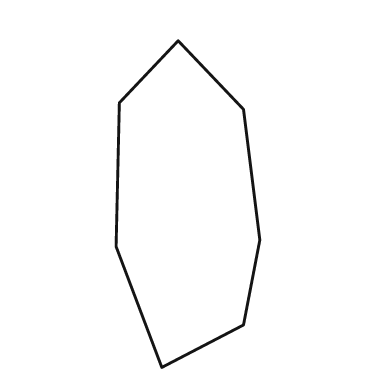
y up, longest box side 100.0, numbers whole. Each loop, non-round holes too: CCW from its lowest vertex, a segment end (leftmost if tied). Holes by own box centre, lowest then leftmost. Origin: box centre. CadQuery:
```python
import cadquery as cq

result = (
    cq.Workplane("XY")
    .moveTo(-8.0, -50.0)
    .lineTo(17.0, -37.0)
    .lineTo(22.0, -11.0)
    .lineTo(17.0, 29.0)
    .lineTo(-3.0, 50.0)
    .lineTo(-21.0, 31.0)
    .lineTo(-22.0, -13.0)
    .close()
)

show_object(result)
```